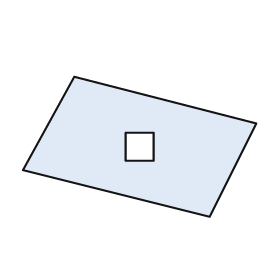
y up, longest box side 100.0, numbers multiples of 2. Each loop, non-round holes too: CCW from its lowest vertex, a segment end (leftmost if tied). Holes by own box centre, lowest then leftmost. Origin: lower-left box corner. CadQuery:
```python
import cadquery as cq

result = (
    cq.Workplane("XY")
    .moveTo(80.0, 0.0)
    .lineTo(100.0, 40.0)
    .lineTo(22.0, 60.0)
    .lineTo(0.0, 20.0)
    .close()
    .moveTo(44.0, 24.0)
    .lineTo(56.0, 24.0)
    .lineTo(56.0, 36.0)
    .lineTo(44.0, 36.0)
    .close()
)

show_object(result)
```